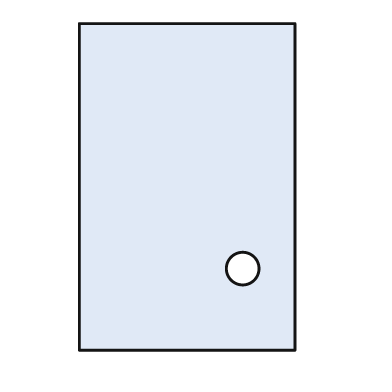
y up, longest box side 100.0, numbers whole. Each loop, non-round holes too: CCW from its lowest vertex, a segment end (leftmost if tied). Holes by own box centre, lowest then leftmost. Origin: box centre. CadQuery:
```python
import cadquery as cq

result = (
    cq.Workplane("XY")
    .moveTo(-33.0, -50.0)
    .lineTo(33.0, -50.0)
    .lineTo(33.0, 50.0)
    .lineTo(-33.0, 50.0)
    .close()
    .moveTo(17.0, -25.0)
    .circle(5.0)
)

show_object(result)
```